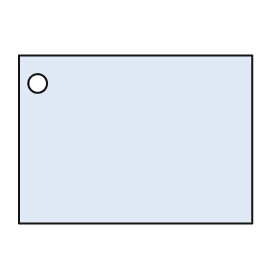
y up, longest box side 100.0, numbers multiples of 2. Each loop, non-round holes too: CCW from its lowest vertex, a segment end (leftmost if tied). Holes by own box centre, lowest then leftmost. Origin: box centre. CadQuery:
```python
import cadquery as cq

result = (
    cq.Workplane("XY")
    .moveTo(-50.0, -36.0)
    .lineTo(50.0, -36.0)
    .lineTo(50.0, 36.0)
    .lineTo(-50.0, 36.0)
    .close()
    .moveTo(-42.0, 24.0)
    .circle(4.0)
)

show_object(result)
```